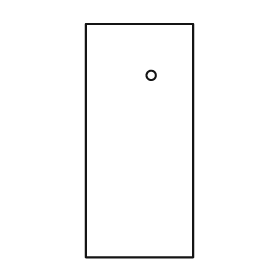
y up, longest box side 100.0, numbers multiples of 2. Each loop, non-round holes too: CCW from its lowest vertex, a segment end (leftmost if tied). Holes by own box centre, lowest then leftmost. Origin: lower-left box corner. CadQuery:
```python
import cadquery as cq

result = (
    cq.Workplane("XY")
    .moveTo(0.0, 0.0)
    .lineTo(46.0, 0.0)
    .lineTo(46.0, 100.0)
    .lineTo(0.0, 100.0)
    .close()
    .moveTo(28.0, 78.0)
    .circle(2.0)
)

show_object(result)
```